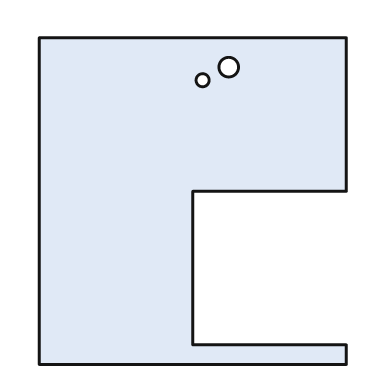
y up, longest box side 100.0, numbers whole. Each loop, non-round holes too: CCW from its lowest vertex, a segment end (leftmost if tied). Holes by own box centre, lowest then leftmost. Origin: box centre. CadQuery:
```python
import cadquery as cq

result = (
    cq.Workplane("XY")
    .moveTo(-47.0, -50.0)
    .lineTo(47.0, -50.0)
    .lineTo(47.0, -44.0)
    .lineTo(0.0, -44.0)
    .lineTo(0.0, 3.0)
    .lineTo(47.0, 3.0)
    .lineTo(47.0, 50.0)
    .lineTo(-47.0, 50.0)
    .close()
    .moveTo(3.0, 37.0)
    .circle(2.0)
    .moveTo(11.0, 41.0)
    .circle(3.0)
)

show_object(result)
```